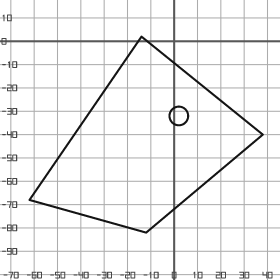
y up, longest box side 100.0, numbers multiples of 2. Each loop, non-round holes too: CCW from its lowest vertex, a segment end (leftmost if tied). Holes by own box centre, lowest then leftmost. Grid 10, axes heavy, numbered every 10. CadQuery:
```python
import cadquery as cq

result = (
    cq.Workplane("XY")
    .moveTo(-12.0, -82.0)
    .lineTo(38.0, -40.0)
    .lineTo(-14.0, 2.0)
    .lineTo(-62.0, -68.0)
    .close()
    .moveTo(2.0, -32.0)
    .circle(4.0)
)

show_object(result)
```